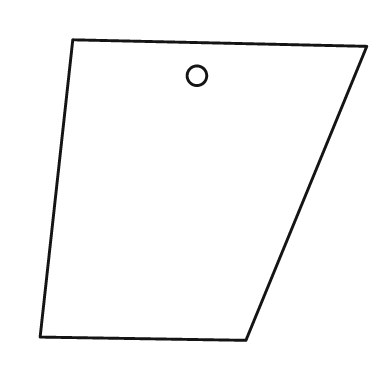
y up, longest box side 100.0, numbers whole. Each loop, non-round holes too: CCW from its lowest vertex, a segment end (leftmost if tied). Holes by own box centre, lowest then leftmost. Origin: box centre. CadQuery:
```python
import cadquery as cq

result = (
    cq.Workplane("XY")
    .moveTo(13.0, -46.0)
    .lineTo(50.0, 44.0)
    .lineTo(-40.0, 46.0)
    .lineTo(-50.0, -45.0)
    .close()
    .moveTo(-2.0, 35.0)
    .circle(3.0)
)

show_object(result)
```